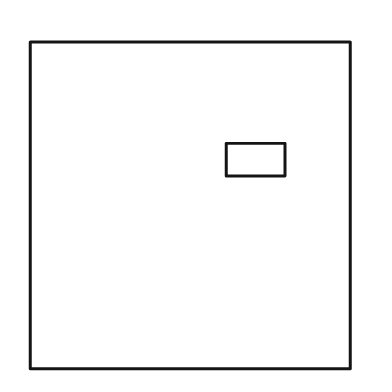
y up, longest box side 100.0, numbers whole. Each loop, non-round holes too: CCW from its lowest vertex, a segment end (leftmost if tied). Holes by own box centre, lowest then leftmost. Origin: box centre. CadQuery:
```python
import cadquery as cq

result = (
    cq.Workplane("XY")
    .moveTo(-49.0, -50.0)
    .lineTo(49.0, -50.0)
    .lineTo(49.0, 50.0)
    .lineTo(-49.0, 50.0)
    .close()
    .moveTo(11.0, 9.0)
    .lineTo(29.0, 9.0)
    .lineTo(29.0, 19.0)
    .lineTo(11.0, 19.0)
    .close()
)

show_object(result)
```